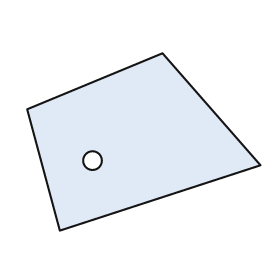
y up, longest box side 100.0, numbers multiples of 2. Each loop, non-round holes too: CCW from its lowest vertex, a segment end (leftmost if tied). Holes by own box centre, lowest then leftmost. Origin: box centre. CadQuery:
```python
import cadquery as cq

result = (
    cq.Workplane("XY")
    .moveTo(-36.0, -38.0)
    .lineTo(50.0, -10.0)
    .lineTo(8.0, 38.0)
    .lineTo(-50.0, 14.0)
    .close()
    .moveTo(-22.0, -8.0)
    .circle(4.0)
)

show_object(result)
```